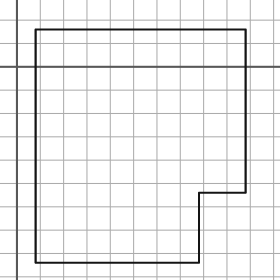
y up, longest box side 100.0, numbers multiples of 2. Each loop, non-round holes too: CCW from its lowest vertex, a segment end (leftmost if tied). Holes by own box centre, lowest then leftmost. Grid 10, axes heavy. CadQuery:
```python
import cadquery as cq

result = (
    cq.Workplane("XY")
    .moveTo(8.0, -84.0)
    .lineTo(78.0, -84.0)
    .lineTo(78.0, -54.0)
    .lineTo(98.0, -54.0)
    .lineTo(98.0, 16.0)
    .lineTo(8.0, 16.0)
    .close()
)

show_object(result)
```